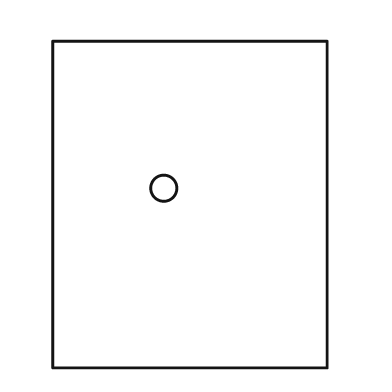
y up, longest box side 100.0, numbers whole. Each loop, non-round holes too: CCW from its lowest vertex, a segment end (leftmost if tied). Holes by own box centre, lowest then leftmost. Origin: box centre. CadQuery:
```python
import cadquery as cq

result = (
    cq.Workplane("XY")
    .moveTo(-42.0, -50.0)
    .lineTo(42.0, -50.0)
    .lineTo(42.0, 50.0)
    .lineTo(-42.0, 50.0)
    .close()
    .moveTo(-8.0, 5.0)
    .circle(4.0)
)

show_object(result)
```